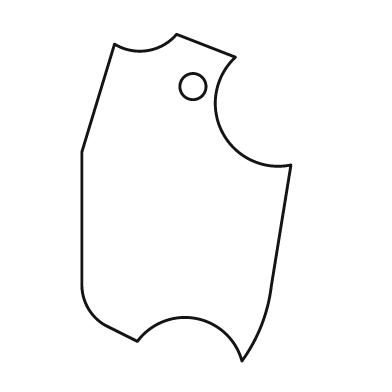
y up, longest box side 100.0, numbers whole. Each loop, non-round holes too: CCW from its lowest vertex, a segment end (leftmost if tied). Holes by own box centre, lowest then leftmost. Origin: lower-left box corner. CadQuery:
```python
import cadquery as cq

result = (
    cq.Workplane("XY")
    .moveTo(49.0, 0.0)
    .threePointArc((55.0, 11.0), (58.0, 23.0))
    .lineTo(64.0, 60.0)
    .threePointArc((43.0, 70.0), (47.0, 93.0))
    .lineTo(29.0, 100.0)
    .threePointArc((20.0, 95.0), (10.0, 97.0))
    .lineTo(0.0, 64.0)
    .lineTo(0.0, 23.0)
    .threePointArc((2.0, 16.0), (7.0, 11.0))
    .lineTo(17.0, 6.0)
    .threePointArc((35.0, 13.0), (49.0, 0.0))
    .close()
    .moveTo(34.0, 84.0)
    .circle(4.0)
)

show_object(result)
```